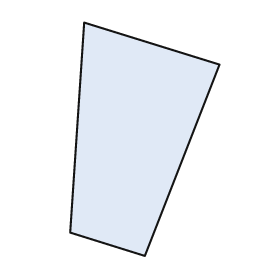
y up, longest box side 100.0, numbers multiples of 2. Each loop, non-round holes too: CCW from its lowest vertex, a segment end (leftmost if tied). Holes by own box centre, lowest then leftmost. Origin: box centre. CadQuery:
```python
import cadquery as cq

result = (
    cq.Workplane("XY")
    .moveTo(0.0, -50.0)
    .lineTo(32.0, 32.0)
    .lineTo(-26.0, 50.0)
    .lineTo(-32.0, -40.0)
    .close()
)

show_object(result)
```